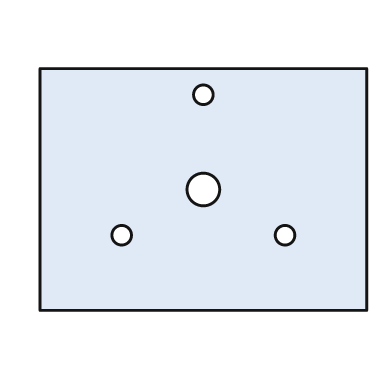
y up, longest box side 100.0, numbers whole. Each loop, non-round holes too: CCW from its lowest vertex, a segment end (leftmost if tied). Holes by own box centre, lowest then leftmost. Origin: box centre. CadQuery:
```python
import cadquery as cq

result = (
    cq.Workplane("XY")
    .moveTo(-50.0, -37.0)
    .lineTo(50.0, -37.0)
    .lineTo(50.0, 37.0)
    .lineTo(-50.0, 37.0)
    .close()
    .moveTo(-25.0, -14.0)
    .circle(3.0)
    .moveTo(25.0, -14.0)
    .circle(3.0)
    .moveTo(0.0, 0.0)
    .circle(5.0)
    .moveTo(0.0, 29.0)
    .circle(3.0)
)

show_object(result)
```